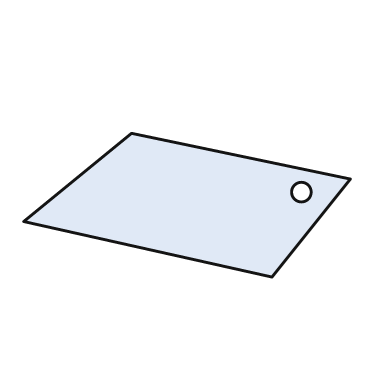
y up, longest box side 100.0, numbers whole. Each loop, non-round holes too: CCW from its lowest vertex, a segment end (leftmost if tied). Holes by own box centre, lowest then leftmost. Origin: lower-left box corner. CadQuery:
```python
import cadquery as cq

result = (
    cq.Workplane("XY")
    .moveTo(76.0, 0.0)
    .lineTo(100.0, 30.0)
    .lineTo(33.0, 44.0)
    .lineTo(0.0, 17.0)
    .close()
    .moveTo(85.0, 26.0)
    .circle(3.0)
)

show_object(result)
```